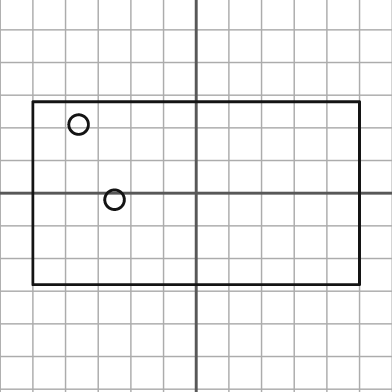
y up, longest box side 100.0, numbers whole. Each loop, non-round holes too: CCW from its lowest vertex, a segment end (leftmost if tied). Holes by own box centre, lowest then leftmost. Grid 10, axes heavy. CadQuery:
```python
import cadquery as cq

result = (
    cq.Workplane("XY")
    .moveTo(-50.0, -28.0)
    .lineTo(50.0, -28.0)
    .lineTo(50.0, 28.0)
    .lineTo(-50.0, 28.0)
    .close()
    .moveTo(-25.0, -2.0)
    .circle(3.0)
    .moveTo(-36.0, 21.0)
    .circle(3.0)
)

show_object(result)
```